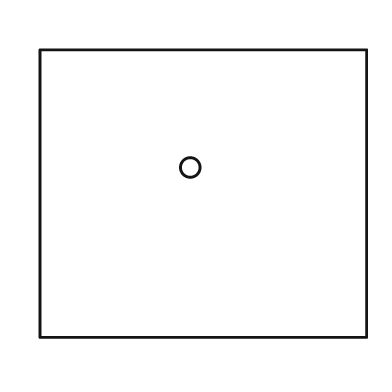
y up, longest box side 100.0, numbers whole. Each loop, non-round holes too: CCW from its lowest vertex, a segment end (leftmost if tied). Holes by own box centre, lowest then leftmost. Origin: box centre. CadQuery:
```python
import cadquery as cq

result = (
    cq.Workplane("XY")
    .moveTo(-50.0, -44.0)
    .lineTo(50.0, -44.0)
    .lineTo(50.0, 44.0)
    .lineTo(-50.0, 44.0)
    .close()
    .moveTo(-4.0, 8.0)
    .circle(3.0)
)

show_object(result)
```